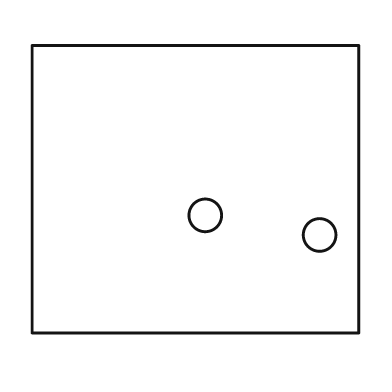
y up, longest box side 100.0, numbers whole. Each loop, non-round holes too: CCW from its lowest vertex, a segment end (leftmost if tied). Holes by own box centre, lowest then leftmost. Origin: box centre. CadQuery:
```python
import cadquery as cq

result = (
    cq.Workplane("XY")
    .moveTo(-50.0, -44.0)
    .lineTo(50.0, -44.0)
    .lineTo(50.0, 44.0)
    .lineTo(-50.0, 44.0)
    .close()
    .moveTo(38.0, -14.0)
    .circle(5.0)
    .moveTo(3.0, -8.0)
    .circle(5.0)
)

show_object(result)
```